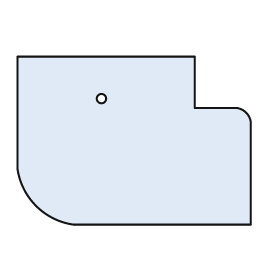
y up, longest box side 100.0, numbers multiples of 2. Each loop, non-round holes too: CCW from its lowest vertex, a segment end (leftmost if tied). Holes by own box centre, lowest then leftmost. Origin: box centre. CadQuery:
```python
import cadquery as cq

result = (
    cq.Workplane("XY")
    .moveTo(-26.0, -36.0)
    .lineTo(50.0, -36.0)
    .lineTo(50.0, 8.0)
    .threePointArc((48.0, 12.0), (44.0, 14.0))
    .lineTo(26.0, 14.0)
    .lineTo(26.0, 36.0)
    .lineTo(-50.0, 36.0)
    .lineTo(-50.0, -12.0)
    .threePointArc((-42.0, -28.0), (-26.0, -36.0))
    .close()
    .moveTo(-14.0, 18.0)
    .circle(2.0)
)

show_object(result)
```